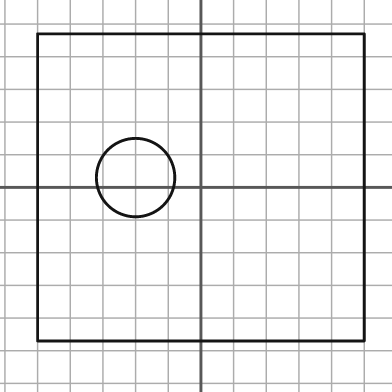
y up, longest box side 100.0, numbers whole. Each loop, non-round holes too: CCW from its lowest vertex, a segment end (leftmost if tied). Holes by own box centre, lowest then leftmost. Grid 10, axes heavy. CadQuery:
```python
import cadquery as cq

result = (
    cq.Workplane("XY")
    .moveTo(-50.0, -47.0)
    .lineTo(50.0, -47.0)
    .lineTo(50.0, 47.0)
    .lineTo(-50.0, 47.0)
    .close()
    .moveTo(-20.0, 3.0)
    .circle(12.0)
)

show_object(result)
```